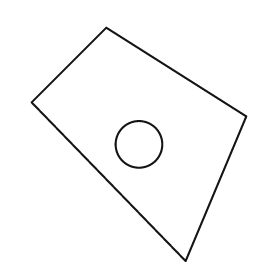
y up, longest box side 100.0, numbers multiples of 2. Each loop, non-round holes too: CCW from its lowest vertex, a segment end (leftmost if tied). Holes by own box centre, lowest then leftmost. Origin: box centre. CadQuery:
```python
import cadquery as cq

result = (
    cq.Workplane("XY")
    .moveTo(20.0, -50.0)
    .lineTo(46.0, 12.0)
    .lineTo(-14.0, 50.0)
    .lineTo(-46.0, 18.0)
    .close()
    .moveTo(0.0, 0.0)
    .circle(10.0)
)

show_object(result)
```